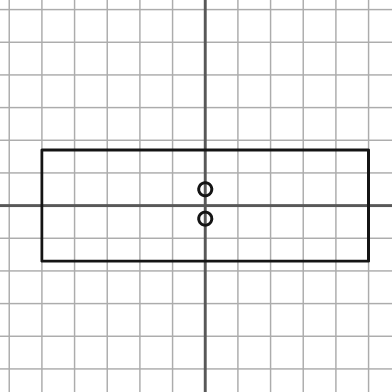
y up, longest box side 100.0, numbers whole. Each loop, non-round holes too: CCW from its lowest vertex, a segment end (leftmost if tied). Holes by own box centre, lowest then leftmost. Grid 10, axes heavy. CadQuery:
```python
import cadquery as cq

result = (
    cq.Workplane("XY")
    .moveTo(-50.0, -17.0)
    .lineTo(50.0, -17.0)
    .lineTo(50.0, 17.0)
    .lineTo(-50.0, 17.0)
    .close()
    .moveTo(0.0, -4.0)
    .circle(2.0)
    .moveTo(0.0, 5.0)
    .circle(2.0)
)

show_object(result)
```